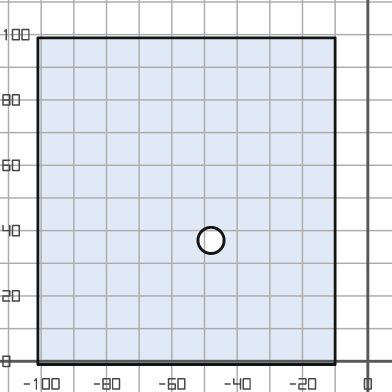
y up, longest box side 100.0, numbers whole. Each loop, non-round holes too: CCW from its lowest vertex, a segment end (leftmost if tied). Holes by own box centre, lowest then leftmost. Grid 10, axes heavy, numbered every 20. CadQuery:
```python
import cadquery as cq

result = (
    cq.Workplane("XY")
    .moveTo(-101.0, -1.0)
    .lineTo(-10.0, -1.0)
    .lineTo(-10.0, 99.0)
    .lineTo(-101.0, 99.0)
    .close()
    .moveTo(-48.0, 37.0)
    .circle(4.0)
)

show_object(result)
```